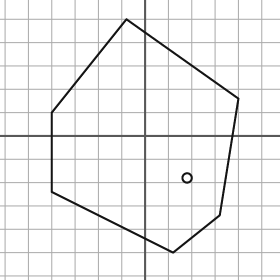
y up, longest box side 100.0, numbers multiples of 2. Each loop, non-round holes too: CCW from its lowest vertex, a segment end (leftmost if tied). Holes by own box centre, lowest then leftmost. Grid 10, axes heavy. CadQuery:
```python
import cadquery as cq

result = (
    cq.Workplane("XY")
    .moveTo(12.0, -50.0)
    .lineTo(32.0, -34.0)
    .lineTo(40.0, 16.0)
    .lineTo(-8.0, 50.0)
    .lineTo(-40.0, 10.0)
    .lineTo(-40.0, -24.0)
    .close()
    .moveTo(18.0, -18.0)
    .circle(2.0)
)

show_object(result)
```